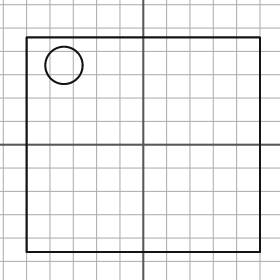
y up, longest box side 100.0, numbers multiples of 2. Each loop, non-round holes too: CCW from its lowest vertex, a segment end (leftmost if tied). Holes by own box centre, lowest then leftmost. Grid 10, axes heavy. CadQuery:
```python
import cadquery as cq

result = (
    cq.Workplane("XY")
    .moveTo(-50.0, -46.0)
    .lineTo(50.0, -46.0)
    .lineTo(50.0, 46.0)
    .lineTo(-50.0, 46.0)
    .close()
    .moveTo(-34.0, 34.0)
    .circle(8.0)
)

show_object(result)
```